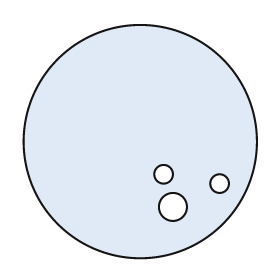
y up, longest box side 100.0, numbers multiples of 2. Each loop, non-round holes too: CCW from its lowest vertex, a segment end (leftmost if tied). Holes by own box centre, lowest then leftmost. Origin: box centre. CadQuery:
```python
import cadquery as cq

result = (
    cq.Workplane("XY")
    .moveTo(0.0, 0.0)
    .circle(50.0)
    .moveTo(14.0, -28.0)
    .circle(6.0)
    .moveTo(34.0, -18.0)
    .circle(4.0)
    .moveTo(10.0, -14.0)
    .circle(4.0)
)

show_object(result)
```